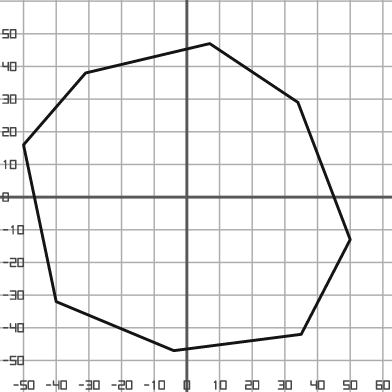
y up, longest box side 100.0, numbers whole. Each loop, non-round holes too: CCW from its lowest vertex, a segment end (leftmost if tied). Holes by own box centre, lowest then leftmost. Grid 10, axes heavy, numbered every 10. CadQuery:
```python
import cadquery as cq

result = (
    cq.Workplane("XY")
    .moveTo(-4.0, -47.0)
    .lineTo(35.0, -42.0)
    .lineTo(50.0, -13.0)
    .lineTo(34.0, 29.0)
    .lineTo(7.0, 47.0)
    .lineTo(-31.0, 38.0)
    .lineTo(-50.0, 16.0)
    .lineTo(-40.0, -32.0)
    .close()
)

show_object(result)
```